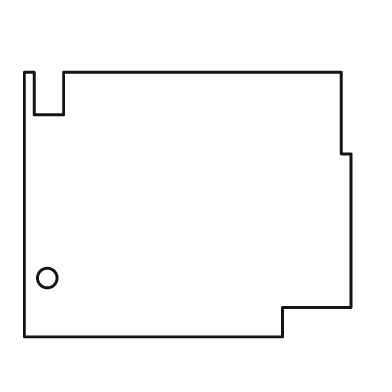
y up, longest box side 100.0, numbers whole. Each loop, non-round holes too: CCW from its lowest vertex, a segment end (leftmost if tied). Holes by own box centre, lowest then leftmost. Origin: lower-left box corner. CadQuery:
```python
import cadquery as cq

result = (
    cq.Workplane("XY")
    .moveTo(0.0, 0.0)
    .lineTo(79.0, 0.0)
    .lineTo(79.0, 9.0)
    .lineTo(100.0, 9.0)
    .lineTo(100.0, 56.0)
    .lineTo(97.0, 56.0)
    .lineTo(97.0, 81.0)
    .lineTo(12.0, 81.0)
    .lineTo(12.0, 68.0)
    .lineTo(3.0, 68.0)
    .lineTo(3.0, 81.0)
    .lineTo(0.0, 81.0)
    .close()
    .moveTo(7.0, 18.0)
    .circle(3.0)
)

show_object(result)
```